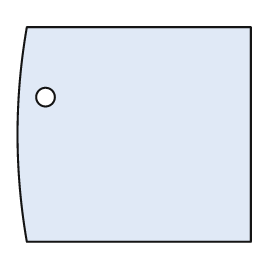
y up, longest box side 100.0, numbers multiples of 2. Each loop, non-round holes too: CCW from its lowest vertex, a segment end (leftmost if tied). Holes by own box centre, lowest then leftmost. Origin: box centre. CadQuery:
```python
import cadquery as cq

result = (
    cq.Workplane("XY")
    .moveTo(-46.0, -46.0)
    .lineTo(50.0, -46.0)
    .lineTo(50.0, 46.0)
    .lineTo(-46.0, 46.0)
    .threePointArc((-50.0, 0.0), (-46.0, -46.0))
    .close()
    .moveTo(-38.0, 16.0)
    .circle(4.0)
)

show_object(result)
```